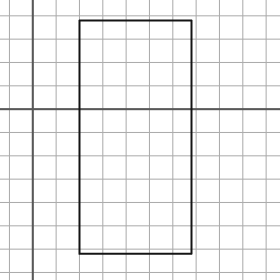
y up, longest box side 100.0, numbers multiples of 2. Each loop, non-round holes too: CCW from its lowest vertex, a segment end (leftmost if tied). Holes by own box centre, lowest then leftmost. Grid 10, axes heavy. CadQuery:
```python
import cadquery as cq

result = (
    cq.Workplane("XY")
    .moveTo(20.0, -62.0)
    .lineTo(68.0, -62.0)
    .lineTo(68.0, 38.0)
    .lineTo(20.0, 38.0)
    .close()
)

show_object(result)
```